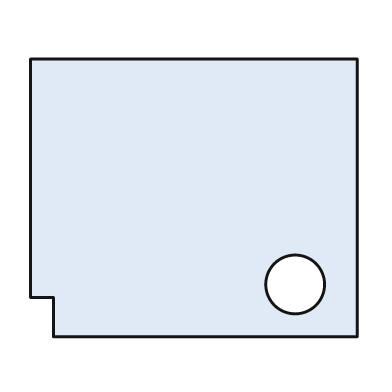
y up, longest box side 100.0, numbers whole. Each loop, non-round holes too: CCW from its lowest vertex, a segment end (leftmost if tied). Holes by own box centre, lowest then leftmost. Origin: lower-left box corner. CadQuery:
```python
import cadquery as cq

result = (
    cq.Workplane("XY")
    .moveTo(7.0, 0.0)
    .lineTo(100.0, 0.0)
    .lineTo(100.0, 85.0)
    .lineTo(0.0, 85.0)
    .lineTo(0.0, 12.0)
    .lineTo(7.0, 12.0)
    .close()
    .moveTo(81.0, 16.0)
    .circle(9.0)
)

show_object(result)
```